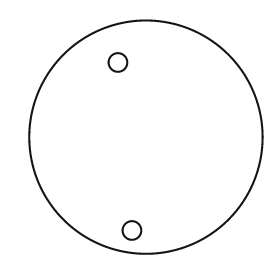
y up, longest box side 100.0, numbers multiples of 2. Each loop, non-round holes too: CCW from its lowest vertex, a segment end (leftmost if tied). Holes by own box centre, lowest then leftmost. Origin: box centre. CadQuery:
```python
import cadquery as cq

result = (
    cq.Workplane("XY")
    .moveTo(0.0, 0.0)
    .circle(50.0)
    .moveTo(-6.0, -40.0)
    .circle(4.0)
    .moveTo(-12.0, 32.0)
    .circle(4.0)
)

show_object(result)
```